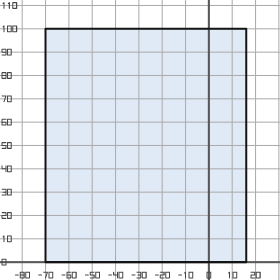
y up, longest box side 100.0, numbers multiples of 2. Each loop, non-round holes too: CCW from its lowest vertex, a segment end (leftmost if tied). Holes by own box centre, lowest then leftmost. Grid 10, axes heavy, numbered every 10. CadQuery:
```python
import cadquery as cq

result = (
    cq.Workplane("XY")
    .moveTo(-70.0, 0.0)
    .lineTo(16.0, 0.0)
    .lineTo(16.0, 100.0)
    .lineTo(-70.0, 100.0)
    .close()
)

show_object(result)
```